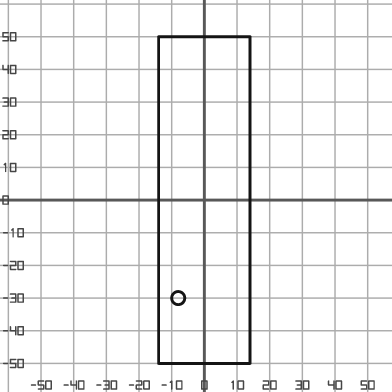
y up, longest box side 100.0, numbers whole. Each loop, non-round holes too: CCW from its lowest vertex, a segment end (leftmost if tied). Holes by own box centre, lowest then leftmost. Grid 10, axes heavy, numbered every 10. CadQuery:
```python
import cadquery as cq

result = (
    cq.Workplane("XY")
    .moveTo(-14.0, -50.0)
    .lineTo(14.0, -50.0)
    .lineTo(14.0, 50.0)
    .lineTo(-14.0, 50.0)
    .close()
    .moveTo(-8.0, -30.0)
    .circle(2.0)
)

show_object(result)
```